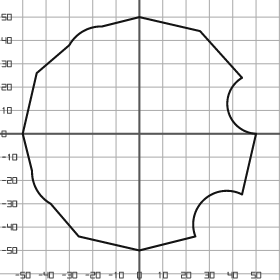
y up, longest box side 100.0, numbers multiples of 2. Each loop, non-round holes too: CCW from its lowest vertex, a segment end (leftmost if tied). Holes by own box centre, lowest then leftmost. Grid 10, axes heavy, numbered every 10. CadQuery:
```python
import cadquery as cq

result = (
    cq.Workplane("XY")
    .moveTo(0.0, -50.0)
    .lineTo(24.0, -44.0)
    .threePointArc((28.0, -28.0), (44.0, -26.0))
    .lineTo(50.0, 0.0)
    .threePointArc((38.0, 10.0), (44.0, 24.0))
    .lineTo(26.0, 44.0)
    .lineTo(0.0, 50.0)
    .lineTo(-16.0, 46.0)
    .threePointArc((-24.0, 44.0), (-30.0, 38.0))
    .lineTo(-44.0, 26.0)
    .lineTo(-50.0, 0.0)
    .lineTo(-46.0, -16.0)
    .threePointArc((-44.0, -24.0), (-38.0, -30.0))
    .lineTo(-26.0, -44.0)
    .close()
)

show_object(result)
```